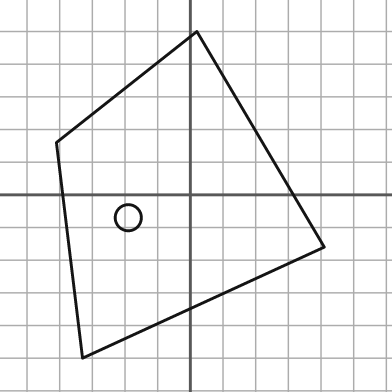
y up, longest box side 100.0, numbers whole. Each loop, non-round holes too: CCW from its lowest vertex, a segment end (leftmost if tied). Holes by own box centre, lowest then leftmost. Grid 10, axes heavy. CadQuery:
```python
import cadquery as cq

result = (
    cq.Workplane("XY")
    .moveTo(-33.0, -50.0)
    .lineTo(41.0, -16.0)
    .lineTo(2.0, 50.0)
    .lineTo(-41.0, 16.0)
    .close()
    .moveTo(-19.0, -7.0)
    .circle(4.0)
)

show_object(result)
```